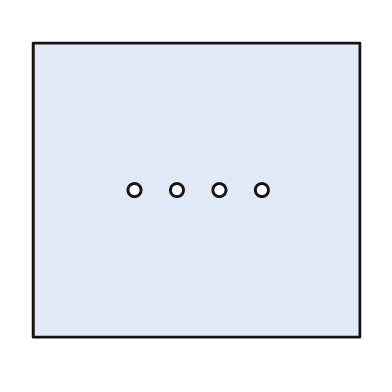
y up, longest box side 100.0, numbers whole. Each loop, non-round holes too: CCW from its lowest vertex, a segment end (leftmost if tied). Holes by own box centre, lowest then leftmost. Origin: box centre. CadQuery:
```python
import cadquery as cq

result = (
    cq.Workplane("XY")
    .moveTo(-50.0, -45.0)
    .lineTo(50.0, -45.0)
    .lineTo(50.0, 45.0)
    .lineTo(-50.0, 45.0)
    .close()
    .moveTo(-19.0, 0.0)
    .circle(2.0)
    .moveTo(-6.0, 0.0)
    .circle(2.0)
    .moveTo(7.0, 0.0)
    .circle(2.0)
    .moveTo(20.0, 0.0)
    .circle(2.0)
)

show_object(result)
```